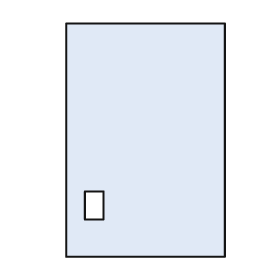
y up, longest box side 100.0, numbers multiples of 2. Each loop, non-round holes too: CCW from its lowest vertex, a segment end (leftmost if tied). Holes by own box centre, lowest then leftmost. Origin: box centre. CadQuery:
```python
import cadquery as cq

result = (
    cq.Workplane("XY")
    .moveTo(-34.0, -50.0)
    .lineTo(34.0, -50.0)
    .lineTo(34.0, 50.0)
    .lineTo(-34.0, 50.0)
    .close()
    .moveTo(-26.0, -34.0)
    .lineTo(-18.0, -34.0)
    .lineTo(-18.0, -22.0)
    .lineTo(-26.0, -22.0)
    .close()
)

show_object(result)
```